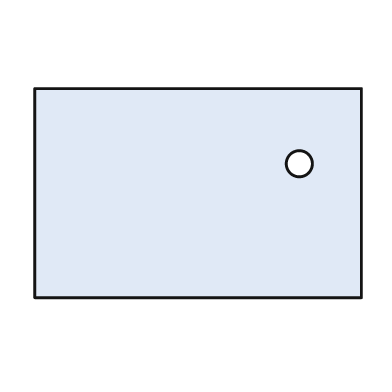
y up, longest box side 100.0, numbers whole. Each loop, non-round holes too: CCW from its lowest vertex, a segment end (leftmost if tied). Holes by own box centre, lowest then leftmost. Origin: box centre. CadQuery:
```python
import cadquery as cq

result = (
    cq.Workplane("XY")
    .moveTo(-50.0, -32.0)
    .lineTo(50.0, -32.0)
    .lineTo(50.0, 32.0)
    .lineTo(-50.0, 32.0)
    .close()
    .moveTo(31.0, 9.0)
    .circle(4.0)
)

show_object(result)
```